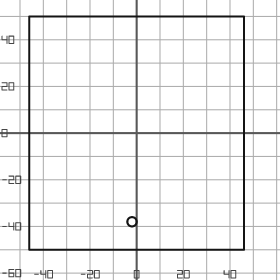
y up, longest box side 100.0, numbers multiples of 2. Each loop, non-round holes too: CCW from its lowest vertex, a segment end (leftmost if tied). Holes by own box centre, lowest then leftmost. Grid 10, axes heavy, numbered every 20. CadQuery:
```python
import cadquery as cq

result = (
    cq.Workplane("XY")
    .moveTo(-46.0, -50.0)
    .lineTo(46.0, -50.0)
    .lineTo(46.0, 50.0)
    .lineTo(-46.0, 50.0)
    .close()
    .moveTo(-2.0, -38.0)
    .circle(2.0)
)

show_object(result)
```